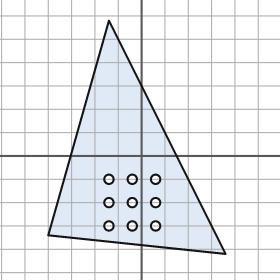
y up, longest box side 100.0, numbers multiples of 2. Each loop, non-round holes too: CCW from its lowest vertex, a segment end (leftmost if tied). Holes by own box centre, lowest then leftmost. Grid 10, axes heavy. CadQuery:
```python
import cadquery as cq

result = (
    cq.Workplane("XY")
    .moveTo(36.0, -42.0)
    .lineTo(-14.0, 58.0)
    .lineTo(-40.0, -34.0)
    .close()
    .moveTo(-14.0, -30.0)
    .circle(2.0)
    .moveTo(-4.0, -30.0)
    .circle(2.0)
    .moveTo(6.0, -30.0)
    .circle(2.0)
    .moveTo(-14.0, -20.0)
    .circle(2.0)
    .moveTo(-4.0, -20.0)
    .circle(2.0)
    .moveTo(6.0, -20.0)
    .circle(2.0)
    .moveTo(-14.0, -10.0)
    .circle(2.0)
    .moveTo(-4.0, -10.0)
    .circle(2.0)
    .moveTo(6.0, -10.0)
    .circle(2.0)
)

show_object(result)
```